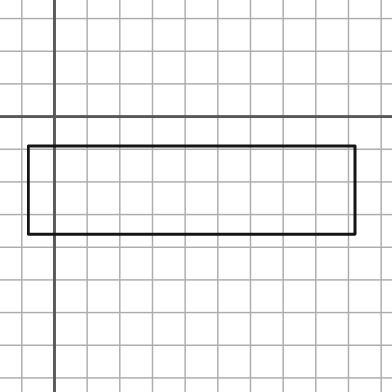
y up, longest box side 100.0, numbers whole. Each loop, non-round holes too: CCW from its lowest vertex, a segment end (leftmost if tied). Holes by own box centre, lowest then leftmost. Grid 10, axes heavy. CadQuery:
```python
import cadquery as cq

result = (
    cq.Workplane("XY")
    .moveTo(-8.0, -36.0)
    .lineTo(92.0, -36.0)
    .lineTo(92.0, -9.0)
    .lineTo(-8.0, -9.0)
    .close()
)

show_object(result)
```